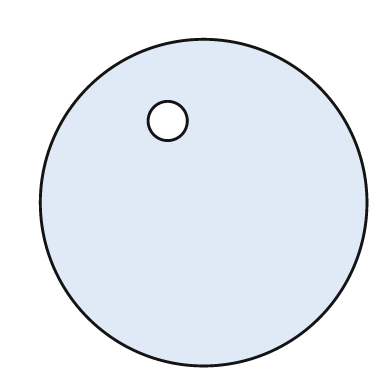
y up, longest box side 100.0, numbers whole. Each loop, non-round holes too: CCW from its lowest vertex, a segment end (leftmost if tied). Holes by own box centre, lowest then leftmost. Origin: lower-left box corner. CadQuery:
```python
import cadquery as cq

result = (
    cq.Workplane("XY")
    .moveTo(50.0, 50.0)
    .circle(50.0)
    .moveTo(39.0, 75.0)
    .circle(6.0)
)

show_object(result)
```